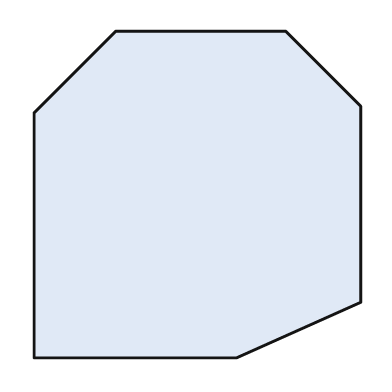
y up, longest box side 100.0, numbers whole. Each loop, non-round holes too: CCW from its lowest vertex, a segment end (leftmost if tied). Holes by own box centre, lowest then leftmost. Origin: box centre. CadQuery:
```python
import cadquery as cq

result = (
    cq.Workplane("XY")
    .moveTo(-50.0, -50.0)
    .lineTo(12.0, -50.0)
    .lineTo(50.0, -33.0)
    .lineTo(50.0, 27.0)
    .lineTo(27.0, 50.0)
    .lineTo(-25.0, 50.0)
    .lineTo(-50.0, 25.0)
    .close()
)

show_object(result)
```